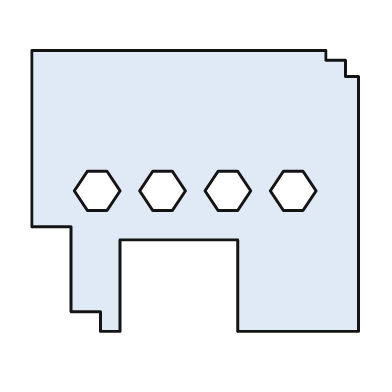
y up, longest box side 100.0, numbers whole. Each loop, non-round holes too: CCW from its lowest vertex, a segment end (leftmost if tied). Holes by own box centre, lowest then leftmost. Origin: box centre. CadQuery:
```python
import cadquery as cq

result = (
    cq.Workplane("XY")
    .moveTo(-29.0, -43.0)
    .lineTo(-23.0, -43.0)
    .lineTo(-23.0, -15.0)
    .lineTo(13.0, -15.0)
    .lineTo(13.0, -43.0)
    .lineTo(50.0, -43.0)
    .lineTo(50.0, 35.0)
    .lineTo(46.0, 35.0)
    .lineTo(46.0, 40.0)
    .lineTo(40.0, 40.0)
    .lineTo(40.0, 43.0)
    .lineTo(-50.0, 43.0)
    .lineTo(-50.0, -11.0)
    .lineTo(-38.0, -11.0)
    .lineTo(-38.0, -37.0)
    .lineTo(-29.0, -37.0)
    .close()
    .moveTo(-33.0, -6.0)
    .lineTo(-27.0, -6.0)
    .lineTo(-23.0, 0.0)
    .lineTo(-27.0, 6.0)
    .lineTo(-33.0, 6.0)
    .lineTo(-37.0, 0.0)
    .close()
    .moveTo(-13.0, -6.0)
    .lineTo(-7.0, -6.0)
    .lineTo(-3.0, 0.0)
    .lineTo(-7.0, 6.0)
    .lineTo(-13.0, 6.0)
    .lineTo(-17.0, 0.0)
    .close()
    .moveTo(7.0, -6.0)
    .lineTo(13.0, -6.0)
    .lineTo(17.0, 0.0)
    .lineTo(13.0, 6.0)
    .lineTo(7.0, 6.0)
    .lineTo(3.0, 0.0)
    .close()
    .moveTo(27.0, -6.0)
    .lineTo(33.0, -6.0)
    .lineTo(37.0, 0.0)
    .lineTo(33.0, 6.0)
    .lineTo(27.0, 6.0)
    .lineTo(23.0, 0.0)
    .close()
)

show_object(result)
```